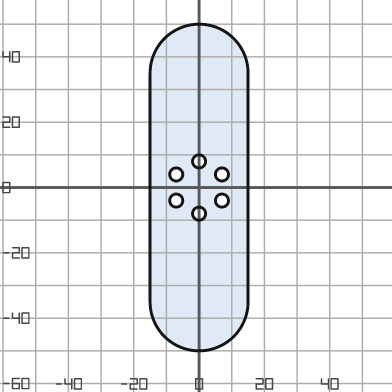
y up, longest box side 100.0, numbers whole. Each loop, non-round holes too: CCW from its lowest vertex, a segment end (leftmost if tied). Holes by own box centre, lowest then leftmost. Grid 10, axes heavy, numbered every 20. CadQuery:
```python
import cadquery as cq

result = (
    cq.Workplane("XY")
    .moveTo(-15.0, -35.0)
    .threePointArc((0.0, -50.0), (15.0, -35.0))
    .lineTo(15.0, 35.0)
    .threePointArc((0.0, 50.0), (-15.0, 35.0))
    .close()
    .moveTo(0.0, -8.0)
    .circle(2.0)
    .moveTo(-7.0, -4.0)
    .circle(2.0)
    .moveTo(7.0, -4.0)
    .circle(2.0)
    .moveTo(-7.0, 4.0)
    .circle(2.0)
    .moveTo(7.0, 4.0)
    .circle(2.0)
    .moveTo(0.0, 8.0)
    .circle(2.0)
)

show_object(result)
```